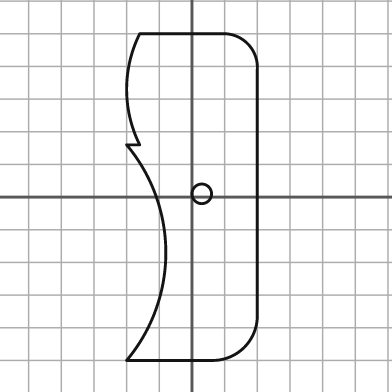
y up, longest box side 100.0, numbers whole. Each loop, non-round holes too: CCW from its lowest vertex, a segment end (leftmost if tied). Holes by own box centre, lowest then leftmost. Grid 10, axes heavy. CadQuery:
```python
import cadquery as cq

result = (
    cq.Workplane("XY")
    .moveTo(-20.0, -50.0)
    .lineTo(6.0, -50.0)
    .threePointArc((16.0, -46.0), (20.0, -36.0))
    .lineTo(20.0, 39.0)
    .threePointArc((17.0, 47.0), (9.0, 50.0))
    .lineTo(-16.0, 50.0)
    .threePointArc((-20.0, 33.0), (-16.0, 16.0))
    .lineTo(-20.0, 16.0)
    .threePointArc((-8.0, -17.0), (-20.0, -50.0))
    .close()
    .moveTo(3.0, 1.0)
    .circle(3.0)
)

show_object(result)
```